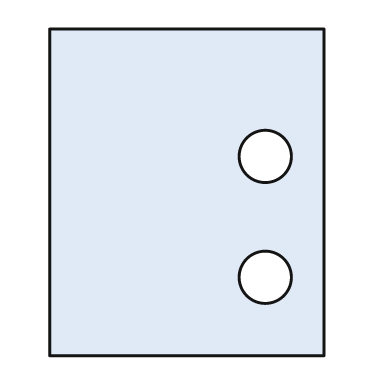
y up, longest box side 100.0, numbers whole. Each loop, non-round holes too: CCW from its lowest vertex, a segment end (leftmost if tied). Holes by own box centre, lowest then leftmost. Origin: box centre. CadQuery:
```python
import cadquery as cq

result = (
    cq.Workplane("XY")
    .moveTo(-42.0, -50.0)
    .lineTo(42.0, -50.0)
    .lineTo(42.0, 50.0)
    .lineTo(-42.0, 50.0)
    .close()
    .moveTo(24.0, -26.0)
    .circle(8.0)
    .moveTo(24.0, 11.0)
    .circle(8.0)
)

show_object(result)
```